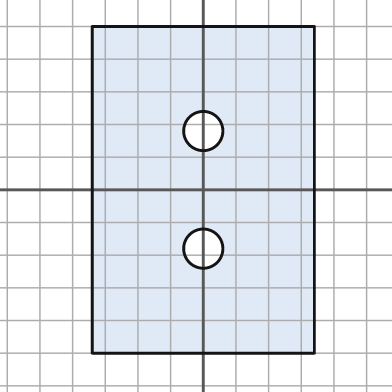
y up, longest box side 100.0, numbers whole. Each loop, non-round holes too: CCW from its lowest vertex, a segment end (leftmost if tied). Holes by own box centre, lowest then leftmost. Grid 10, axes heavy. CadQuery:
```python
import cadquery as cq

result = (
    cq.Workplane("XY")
    .moveTo(-34.0, -50.0)
    .lineTo(34.0, -50.0)
    .lineTo(34.0, 50.0)
    .lineTo(-34.0, 50.0)
    .close()
    .moveTo(0.0, -18.0)
    .circle(6.0)
    .moveTo(0.0, 18.0)
    .circle(6.0)
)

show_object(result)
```